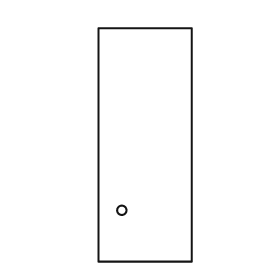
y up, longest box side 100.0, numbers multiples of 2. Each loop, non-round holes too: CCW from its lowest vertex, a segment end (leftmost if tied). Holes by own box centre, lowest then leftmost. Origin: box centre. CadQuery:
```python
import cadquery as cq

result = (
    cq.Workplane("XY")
    .moveTo(-20.0, -50.0)
    .lineTo(20.0, -50.0)
    .lineTo(20.0, 50.0)
    .lineTo(-20.0, 50.0)
    .close()
    .moveTo(-10.0, -28.0)
    .circle(2.0)
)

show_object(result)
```